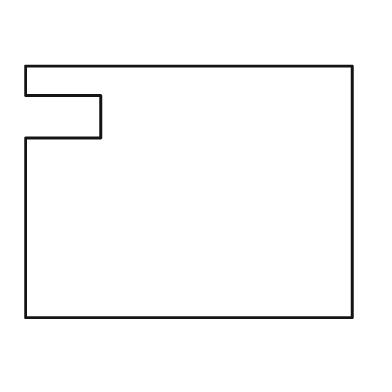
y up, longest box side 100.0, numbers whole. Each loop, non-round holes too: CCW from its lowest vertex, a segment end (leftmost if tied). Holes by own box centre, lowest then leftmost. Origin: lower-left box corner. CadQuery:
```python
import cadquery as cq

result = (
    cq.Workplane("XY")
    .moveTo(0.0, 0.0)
    .lineTo(100.0, 0.0)
    .lineTo(100.0, 77.0)
    .lineTo(0.0, 77.0)
    .lineTo(0.0, 68.0)
    .lineTo(23.0, 68.0)
    .lineTo(23.0, 55.0)
    .lineTo(0.0, 55.0)
    .close()
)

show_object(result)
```